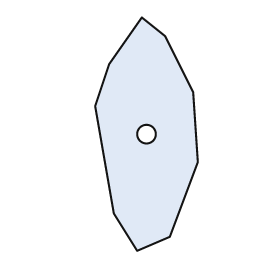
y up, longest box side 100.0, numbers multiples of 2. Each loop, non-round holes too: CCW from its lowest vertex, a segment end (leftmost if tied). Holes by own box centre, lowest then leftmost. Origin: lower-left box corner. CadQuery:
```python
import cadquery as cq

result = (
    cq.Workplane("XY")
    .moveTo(18.0, 0.0)
    .lineTo(32.0, 6.0)
    .lineTo(44.0, 38.0)
    .lineTo(42.0, 68.0)
    .lineTo(30.0, 92.0)
    .lineTo(20.0, 100.0)
    .lineTo(6.0, 80.0)
    .lineTo(0.0, 62.0)
    .lineTo(8.0, 16.0)
    .close()
    .moveTo(22.0, 50.0)
    .circle(4.0)
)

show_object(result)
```